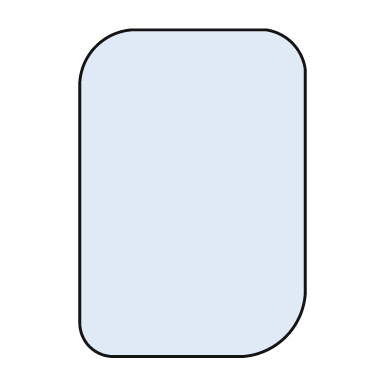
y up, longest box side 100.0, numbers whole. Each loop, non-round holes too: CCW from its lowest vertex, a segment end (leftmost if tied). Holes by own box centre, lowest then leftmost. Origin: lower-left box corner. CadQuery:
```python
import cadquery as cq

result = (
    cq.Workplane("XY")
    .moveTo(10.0, 0.0)
    .lineTo(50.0, 0.0)
    .threePointArc((63.0, 6.0), (69.0, 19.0))
    .lineTo(69.0, 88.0)
    .threePointArc((65.0, 96.0), (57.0, 100.0))
    .lineTo(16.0, 100.0)
    .threePointArc((5.0, 95.0), (0.0, 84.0))
    .lineTo(0.0, 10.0)
    .threePointArc((3.0, 3.0), (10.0, 0.0))
    .close()
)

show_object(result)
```